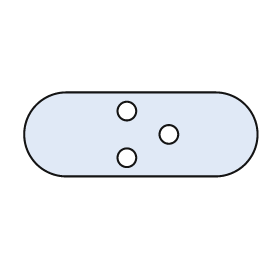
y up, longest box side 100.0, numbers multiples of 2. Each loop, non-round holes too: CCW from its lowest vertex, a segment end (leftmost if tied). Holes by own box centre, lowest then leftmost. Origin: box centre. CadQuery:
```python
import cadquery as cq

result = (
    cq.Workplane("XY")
    .moveTo(-32.0, -18.0)
    .lineTo(32.0, -18.0)
    .threePointArc((50.0, 0.0), (32.0, 18.0))
    .lineTo(-32.0, 18.0)
    .threePointArc((-50.0, 0.0), (-32.0, -18.0))
    .close()
    .moveTo(-6.0, -10.0)
    .circle(4.0)
    .moveTo(12.0, 0.0)
    .circle(4.0)
    .moveTo(-6.0, 10.0)
    .circle(4.0)
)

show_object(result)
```